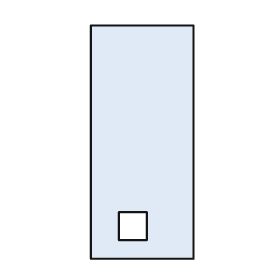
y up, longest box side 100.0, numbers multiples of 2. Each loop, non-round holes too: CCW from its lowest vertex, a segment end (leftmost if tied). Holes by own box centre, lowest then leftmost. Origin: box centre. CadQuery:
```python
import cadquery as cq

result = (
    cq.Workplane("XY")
    .moveTo(-22.0, -50.0)
    .lineTo(22.0, -50.0)
    .lineTo(22.0, 50.0)
    .lineTo(-22.0, 50.0)
    .close()
    .moveTo(-10.0, -42.0)
    .lineTo(2.0, -42.0)
    .lineTo(2.0, -30.0)
    .lineTo(-10.0, -30.0)
    .close()
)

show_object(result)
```